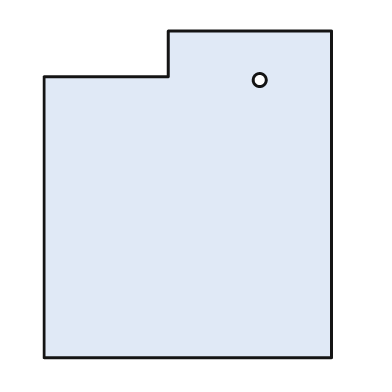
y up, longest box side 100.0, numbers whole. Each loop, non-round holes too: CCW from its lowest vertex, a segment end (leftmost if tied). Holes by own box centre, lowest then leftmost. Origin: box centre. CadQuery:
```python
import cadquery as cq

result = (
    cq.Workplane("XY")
    .moveTo(-44.0, -50.0)
    .lineTo(44.0, -50.0)
    .lineTo(44.0, 50.0)
    .lineTo(-6.0, 50.0)
    .lineTo(-6.0, 36.0)
    .lineTo(-44.0, 36.0)
    .close()
    .moveTo(22.0, 35.0)
    .circle(2.0)
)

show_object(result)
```